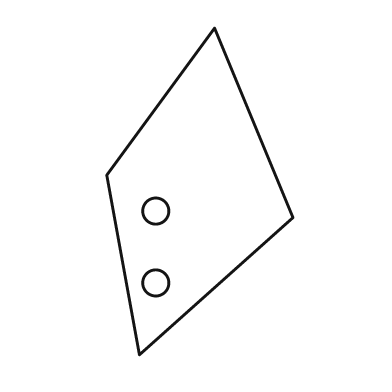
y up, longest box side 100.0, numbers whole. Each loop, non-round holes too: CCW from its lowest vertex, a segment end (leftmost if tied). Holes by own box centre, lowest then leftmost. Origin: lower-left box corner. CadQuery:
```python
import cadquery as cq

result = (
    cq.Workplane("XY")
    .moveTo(10.0, 0.0)
    .lineTo(57.0, 42.0)
    .lineTo(33.0, 100.0)
    .lineTo(0.0, 55.0)
    .close()
    .moveTo(15.0, 22.0)
    .circle(4.0)
    .moveTo(15.0, 44.0)
    .circle(4.0)
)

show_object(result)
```